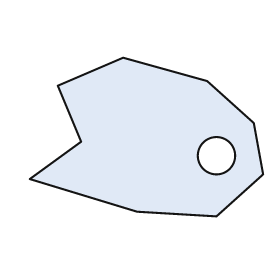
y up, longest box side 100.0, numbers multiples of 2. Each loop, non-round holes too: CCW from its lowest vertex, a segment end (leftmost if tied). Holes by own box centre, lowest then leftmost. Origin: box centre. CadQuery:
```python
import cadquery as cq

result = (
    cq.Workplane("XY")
    .moveTo(30.0, -34.0)
    .lineTo(50.0, -16.0)
    .lineTo(46.0, 6.0)
    .lineTo(26.0, 24.0)
    .lineTo(-10.0, 34.0)
    .lineTo(-38.0, 22.0)
    .lineTo(-28.0, -2.0)
    .lineTo(-50.0, -18.0)
    .lineTo(-4.0, -32.0)
    .close()
    .moveTo(30.0, -8.0)
    .circle(8.0)
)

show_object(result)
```